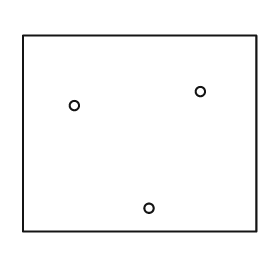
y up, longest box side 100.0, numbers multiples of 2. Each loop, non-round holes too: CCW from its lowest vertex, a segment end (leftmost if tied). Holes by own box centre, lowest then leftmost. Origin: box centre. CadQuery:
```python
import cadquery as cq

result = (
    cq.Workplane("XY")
    .moveTo(-50.0, -42.0)
    .lineTo(50.0, -42.0)
    .lineTo(50.0, 42.0)
    .lineTo(-50.0, 42.0)
    .close()
    .moveTo(4.0, -32.0)
    .circle(2.0)
    .moveTo(-28.0, 12.0)
    .circle(2.0)
    .moveTo(26.0, 18.0)
    .circle(2.0)
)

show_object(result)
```